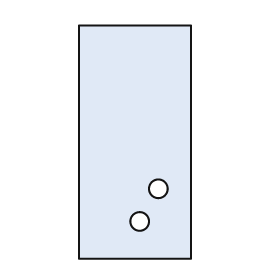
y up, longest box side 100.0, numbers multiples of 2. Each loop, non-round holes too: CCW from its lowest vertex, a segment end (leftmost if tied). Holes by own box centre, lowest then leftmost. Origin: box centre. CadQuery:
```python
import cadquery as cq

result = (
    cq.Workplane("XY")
    .moveTo(-24.0, -50.0)
    .lineTo(24.0, -50.0)
    .lineTo(24.0, 50.0)
    .lineTo(-24.0, 50.0)
    .close()
    .moveTo(2.0, -34.0)
    .circle(4.0)
    .moveTo(10.0, -20.0)
    .circle(4.0)
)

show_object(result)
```